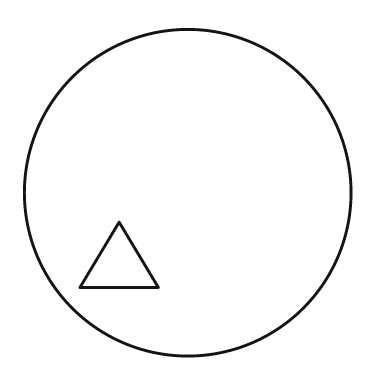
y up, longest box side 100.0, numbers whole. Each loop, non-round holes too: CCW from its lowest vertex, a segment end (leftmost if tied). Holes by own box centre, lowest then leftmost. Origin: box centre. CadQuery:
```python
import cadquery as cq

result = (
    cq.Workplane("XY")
    .moveTo(0.0, 0.0)
    .circle(50.0)
    .moveTo(-33.0, -29.0)
    .lineTo(-9.0, -29.0)
    .lineTo(-21.0, -9.0)
    .close()
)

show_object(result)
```